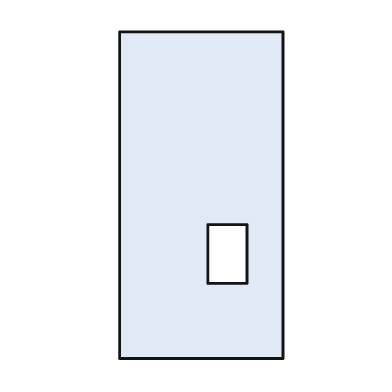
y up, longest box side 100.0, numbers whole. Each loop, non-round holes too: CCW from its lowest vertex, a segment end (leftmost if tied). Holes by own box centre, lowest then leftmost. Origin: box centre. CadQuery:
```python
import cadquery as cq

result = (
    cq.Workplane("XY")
    .moveTo(-25.0, -50.0)
    .lineTo(25.0, -50.0)
    .lineTo(25.0, 50.0)
    .lineTo(-25.0, 50.0)
    .close()
    .moveTo(2.0, -27.0)
    .lineTo(14.0, -27.0)
    .lineTo(14.0, -9.0)
    .lineTo(2.0, -9.0)
    .close()
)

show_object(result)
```